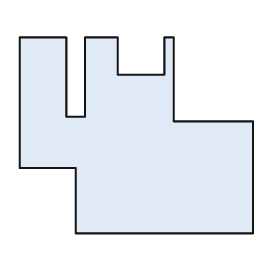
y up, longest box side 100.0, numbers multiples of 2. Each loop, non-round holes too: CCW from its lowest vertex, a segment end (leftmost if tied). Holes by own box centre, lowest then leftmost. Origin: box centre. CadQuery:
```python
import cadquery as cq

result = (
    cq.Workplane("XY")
    .moveTo(-26.0, -42.0)
    .lineTo(50.0, -42.0)
    .lineTo(50.0, 6.0)
    .lineTo(16.0, 6.0)
    .lineTo(16.0, 42.0)
    .lineTo(12.0, 42.0)
    .lineTo(12.0, 26.0)
    .lineTo(-8.0, 26.0)
    .lineTo(-8.0, 42.0)
    .lineTo(-22.0, 42.0)
    .lineTo(-22.0, 8.0)
    .lineTo(-30.0, 8.0)
    .lineTo(-30.0, 42.0)
    .lineTo(-50.0, 42.0)
    .lineTo(-50.0, -14.0)
    .lineTo(-26.0, -14.0)
    .close()
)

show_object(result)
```